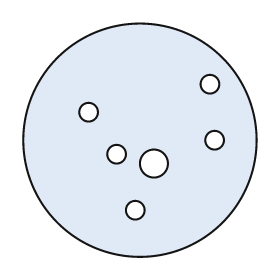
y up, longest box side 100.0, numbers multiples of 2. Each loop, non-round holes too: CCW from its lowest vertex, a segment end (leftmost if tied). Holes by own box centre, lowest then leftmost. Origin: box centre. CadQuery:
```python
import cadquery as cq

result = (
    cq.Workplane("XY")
    .moveTo(0.0, 0.0)
    .circle(50.0)
    .moveTo(-2.0, -30.0)
    .circle(4.0)
    .moveTo(6.0, -10.0)
    .circle(6.0)
    .moveTo(-10.0, -6.0)
    .circle(4.0)
    .moveTo(32.0, 0.0)
    .circle(4.0)
    .moveTo(-22.0, 12.0)
    .circle(4.0)
    .moveTo(30.0, 24.0)
    .circle(4.0)
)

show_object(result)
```